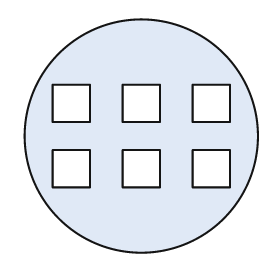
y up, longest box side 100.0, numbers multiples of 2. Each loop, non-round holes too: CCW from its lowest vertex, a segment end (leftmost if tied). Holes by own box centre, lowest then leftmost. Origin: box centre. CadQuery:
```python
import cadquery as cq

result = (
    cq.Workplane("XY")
    .moveTo(0.0, 0.0)
    .circle(50.0)
    .moveTo(-38.0, -22.0)
    .lineTo(-22.0, -22.0)
    .lineTo(-22.0, -6.0)
    .lineTo(-38.0, -6.0)
    .close()
    .moveTo(-8.0, -22.0)
    .lineTo(8.0, -22.0)
    .lineTo(8.0, -6.0)
    .lineTo(-8.0, -6.0)
    .close()
    .moveTo(22.0, -22.0)
    .lineTo(38.0, -22.0)
    .lineTo(38.0, -6.0)
    .lineTo(22.0, -6.0)
    .close()
    .moveTo(-38.0, 6.0)
    .lineTo(-22.0, 6.0)
    .lineTo(-22.0, 22.0)
    .lineTo(-38.0, 22.0)
    .close()
    .moveTo(-8.0, 6.0)
    .lineTo(8.0, 6.0)
    .lineTo(8.0, 22.0)
    .lineTo(-8.0, 22.0)
    .close()
    .moveTo(22.0, 6.0)
    .lineTo(38.0, 6.0)
    .lineTo(38.0, 22.0)
    .lineTo(22.0, 22.0)
    .close()
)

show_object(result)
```